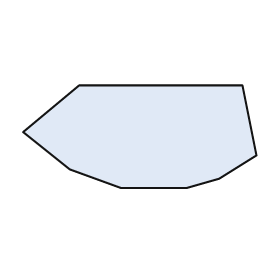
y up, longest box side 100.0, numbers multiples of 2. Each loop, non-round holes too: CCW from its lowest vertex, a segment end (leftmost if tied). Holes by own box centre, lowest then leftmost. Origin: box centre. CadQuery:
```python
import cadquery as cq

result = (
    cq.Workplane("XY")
    .moveTo(-8.0, -22.0)
    .lineTo(20.0, -22.0)
    .lineTo(34.0, -18.0)
    .lineTo(50.0, -8.0)
    .lineTo(44.0, 22.0)
    .lineTo(-26.0, 22.0)
    .lineTo(-50.0, 2.0)
    .lineTo(-30.0, -14.0)
    .close()
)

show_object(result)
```